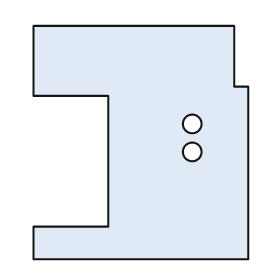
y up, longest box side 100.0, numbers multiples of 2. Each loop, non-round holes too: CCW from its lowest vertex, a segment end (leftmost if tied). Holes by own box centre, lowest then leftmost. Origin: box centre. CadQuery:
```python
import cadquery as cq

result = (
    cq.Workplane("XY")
    .moveTo(-46.0, -50.0)
    .lineTo(46.0, -50.0)
    .lineTo(46.0, 24.0)
    .lineTo(40.0, 24.0)
    .lineTo(40.0, 50.0)
    .lineTo(-46.0, 50.0)
    .lineTo(-46.0, 20.0)
    .lineTo(-14.0, 20.0)
    .lineTo(-14.0, -36.0)
    .lineTo(-46.0, -36.0)
    .close()
    .moveTo(22.0, -4.0)
    .circle(4.0)
    .moveTo(22.0, 8.0)
    .circle(4.0)
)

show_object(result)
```